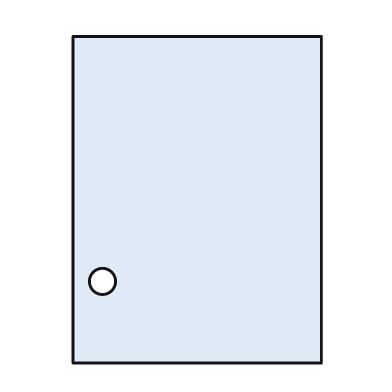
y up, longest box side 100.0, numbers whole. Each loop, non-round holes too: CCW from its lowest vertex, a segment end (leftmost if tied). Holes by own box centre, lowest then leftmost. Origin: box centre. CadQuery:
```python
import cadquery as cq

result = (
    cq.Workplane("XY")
    .moveTo(-38.0, -50.0)
    .lineTo(38.0, -50.0)
    .lineTo(38.0, 50.0)
    .lineTo(-38.0, 50.0)
    .close()
    .moveTo(-29.0, -25.0)
    .circle(4.0)
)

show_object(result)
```